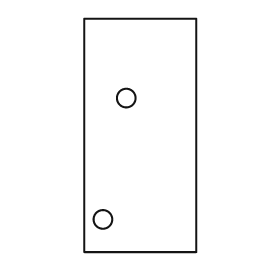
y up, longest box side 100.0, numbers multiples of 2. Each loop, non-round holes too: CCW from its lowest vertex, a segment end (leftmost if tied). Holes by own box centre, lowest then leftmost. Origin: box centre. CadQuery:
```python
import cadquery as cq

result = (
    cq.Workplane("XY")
    .moveTo(-24.0, -50.0)
    .lineTo(24.0, -50.0)
    .lineTo(24.0, 50.0)
    .lineTo(-24.0, 50.0)
    .close()
    .moveTo(-16.0, -36.0)
    .circle(4.0)
    .moveTo(-6.0, 16.0)
    .circle(4.0)
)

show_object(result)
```